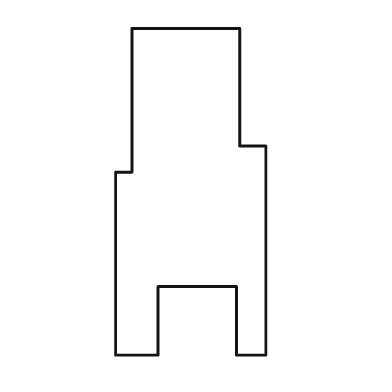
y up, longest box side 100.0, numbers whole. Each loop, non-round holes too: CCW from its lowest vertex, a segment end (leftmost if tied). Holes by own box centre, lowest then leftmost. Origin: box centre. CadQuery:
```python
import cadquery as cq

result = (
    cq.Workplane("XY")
    .moveTo(-23.0, -50.0)
    .lineTo(-10.0, -50.0)
    .lineTo(-10.0, -29.0)
    .lineTo(14.0, -29.0)
    .lineTo(14.0, -50.0)
    .lineTo(23.0, -50.0)
    .lineTo(23.0, 14.0)
    .lineTo(15.0, 14.0)
    .lineTo(15.0, 50.0)
    .lineTo(-18.0, 50.0)
    .lineTo(-18.0, 6.0)
    .lineTo(-23.0, 6.0)
    .close()
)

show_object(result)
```